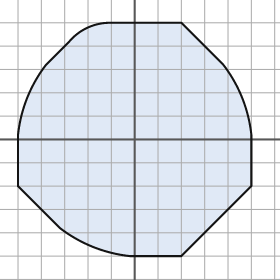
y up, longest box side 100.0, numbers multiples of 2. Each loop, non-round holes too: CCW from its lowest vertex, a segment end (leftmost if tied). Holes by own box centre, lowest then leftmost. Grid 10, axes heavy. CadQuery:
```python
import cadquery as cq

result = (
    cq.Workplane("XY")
    .moveTo(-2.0, -50.0)
    .lineTo(20.0, -50.0)
    .lineTo(50.0, -20.0)
    .lineTo(50.0, 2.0)
    .threePointArc((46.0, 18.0), (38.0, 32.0))
    .lineTo(20.0, 50.0)
    .lineTo(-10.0, 50.0)
    .threePointArc((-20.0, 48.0), (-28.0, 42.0))
    .lineTo(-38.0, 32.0)
    .threePointArc((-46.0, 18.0), (-50.0, 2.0))
    .lineTo(-50.0, -20.0)
    .lineTo(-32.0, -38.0)
    .threePointArc((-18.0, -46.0), (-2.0, -50.0))
    .close()
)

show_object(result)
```